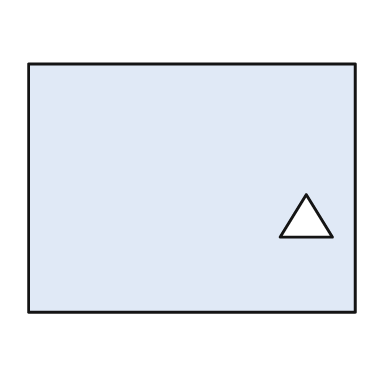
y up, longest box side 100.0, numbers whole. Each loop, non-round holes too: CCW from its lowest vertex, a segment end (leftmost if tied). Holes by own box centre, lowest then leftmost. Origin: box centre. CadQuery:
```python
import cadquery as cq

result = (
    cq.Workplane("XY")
    .moveTo(-50.0, -38.0)
    .lineTo(50.0, -38.0)
    .lineTo(50.0, 38.0)
    .lineTo(-50.0, 38.0)
    .close()
    .moveTo(27.0, -15.0)
    .lineTo(43.0, -15.0)
    .lineTo(35.0, -2.0)
    .close()
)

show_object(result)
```